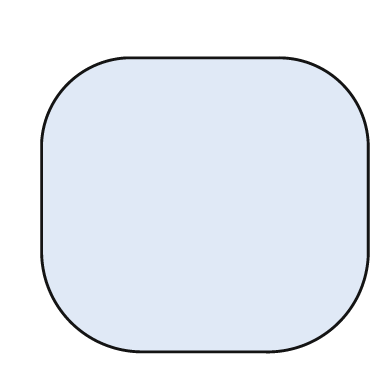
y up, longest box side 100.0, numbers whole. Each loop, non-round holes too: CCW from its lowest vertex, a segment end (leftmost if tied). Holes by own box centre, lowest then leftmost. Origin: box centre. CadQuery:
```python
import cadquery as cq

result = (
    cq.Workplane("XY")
    .moveTo(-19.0, -45.0)
    .lineTo(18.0, -45.0)
    .threePointArc((41.0, -36.0), (50.0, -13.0))
    .lineTo(50.0, 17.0)
    .threePointArc((42.0, 37.0), (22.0, 45.0))
    .lineTo(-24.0, 45.0)
    .threePointArc((-42.0, 37.0), (-50.0, 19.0))
    .lineTo(-50.0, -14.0)
    .threePointArc((-41.0, -36.0), (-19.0, -45.0))
    .close()
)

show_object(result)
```